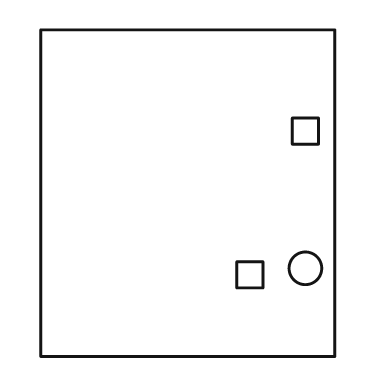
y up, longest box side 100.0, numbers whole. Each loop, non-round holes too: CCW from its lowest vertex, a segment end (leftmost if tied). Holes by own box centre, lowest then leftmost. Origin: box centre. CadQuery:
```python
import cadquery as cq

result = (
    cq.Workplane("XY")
    .moveTo(-45.0, -50.0)
    .lineTo(45.0, -50.0)
    .lineTo(45.0, 50.0)
    .lineTo(-45.0, 50.0)
    .close()
    .moveTo(15.0, -29.0)
    .lineTo(23.0, -29.0)
    .lineTo(23.0, -21.0)
    .lineTo(15.0, -21.0)
    .close()
    .moveTo(36.0, -23.0)
    .circle(5.0)
    .moveTo(32.0, 15.0)
    .lineTo(40.0, 15.0)
    .lineTo(40.0, 23.0)
    .lineTo(32.0, 23.0)
    .close()
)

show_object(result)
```